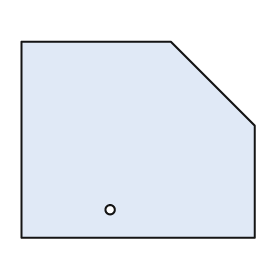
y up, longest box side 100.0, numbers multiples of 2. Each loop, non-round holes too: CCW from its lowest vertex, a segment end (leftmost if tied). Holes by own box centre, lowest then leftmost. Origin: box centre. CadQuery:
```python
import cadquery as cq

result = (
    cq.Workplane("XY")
    .moveTo(-50.0, -42.0)
    .lineTo(50.0, -42.0)
    .lineTo(50.0, 6.0)
    .lineTo(14.0, 42.0)
    .lineTo(-50.0, 42.0)
    .close()
    .moveTo(-12.0, -30.0)
    .circle(2.0)
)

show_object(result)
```